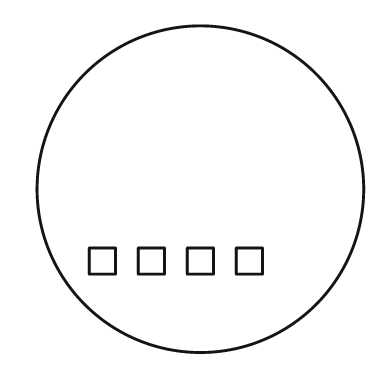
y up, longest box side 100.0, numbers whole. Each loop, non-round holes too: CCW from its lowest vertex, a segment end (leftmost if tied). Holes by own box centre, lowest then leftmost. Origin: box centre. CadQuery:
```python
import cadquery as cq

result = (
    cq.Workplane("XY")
    .moveTo(0.0, 0.0)
    .circle(50.0)
    .moveTo(-34.0, -26.0)
    .lineTo(-26.0, -26.0)
    .lineTo(-26.0, -18.0)
    .lineTo(-34.0, -18.0)
    .close()
    .moveTo(-19.0, -26.0)
    .lineTo(-11.0, -26.0)
    .lineTo(-11.0, -18.0)
    .lineTo(-19.0, -18.0)
    .close()
    .moveTo(-4.0, -26.0)
    .lineTo(4.0, -26.0)
    .lineTo(4.0, -18.0)
    .lineTo(-4.0, -18.0)
    .close()
    .moveTo(11.0, -26.0)
    .lineTo(19.0, -26.0)
    .lineTo(19.0, -18.0)
    .lineTo(11.0, -18.0)
    .close()
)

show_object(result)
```